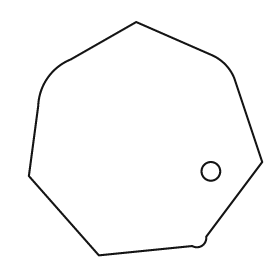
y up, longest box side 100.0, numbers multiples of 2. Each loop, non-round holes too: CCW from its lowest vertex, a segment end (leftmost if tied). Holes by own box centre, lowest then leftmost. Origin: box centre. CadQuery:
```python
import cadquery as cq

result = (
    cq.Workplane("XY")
    .moveTo(-20.0, -50.0)
    .lineTo(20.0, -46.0)
    .threePointArc((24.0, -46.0), (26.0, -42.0))
    .lineTo(50.0, -10.0)
    .lineTo(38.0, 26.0)
    .threePointArc((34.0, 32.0), (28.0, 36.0))
    .lineTo(-4.0, 50.0)
    .lineTo(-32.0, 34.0)
    .threePointArc((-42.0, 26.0), (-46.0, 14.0))
    .lineTo(-50.0, -16.0)
    .close()
    .moveTo(28.0, -14.0)
    .circle(4.0)
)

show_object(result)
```